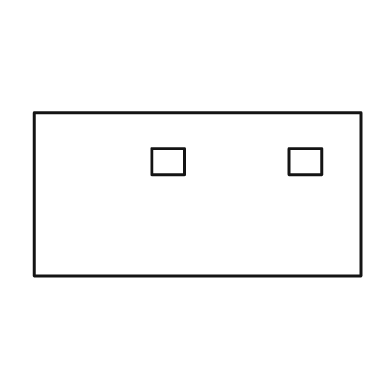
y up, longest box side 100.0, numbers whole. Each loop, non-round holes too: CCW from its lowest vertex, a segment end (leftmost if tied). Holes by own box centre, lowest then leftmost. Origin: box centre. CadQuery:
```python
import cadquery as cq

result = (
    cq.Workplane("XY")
    .moveTo(-50.0, -25.0)
    .lineTo(50.0, -25.0)
    .lineTo(50.0, 25.0)
    .lineTo(-50.0, 25.0)
    .close()
    .moveTo(-14.0, 6.0)
    .lineTo(-4.0, 6.0)
    .lineTo(-4.0, 14.0)
    .lineTo(-14.0, 14.0)
    .close()
    .moveTo(28.0, 6.0)
    .lineTo(38.0, 6.0)
    .lineTo(38.0, 14.0)
    .lineTo(28.0, 14.0)
    .close()
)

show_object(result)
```